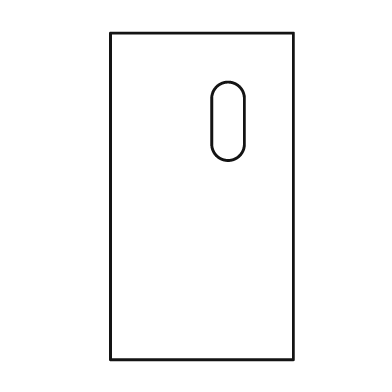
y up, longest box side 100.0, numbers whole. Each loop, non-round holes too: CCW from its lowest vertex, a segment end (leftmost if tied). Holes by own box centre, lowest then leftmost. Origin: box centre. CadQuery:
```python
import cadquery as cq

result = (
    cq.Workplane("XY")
    .moveTo(-28.0, -50.0)
    .lineTo(28.0, -50.0)
    .lineTo(28.0, 50.0)
    .lineTo(-28.0, 50.0)
    .close()
    .moveTo(3.0, 16.0)
    .threePointArc((8.0, 11.0), (13.0, 16.0))
    .lineTo(13.0, 30.0)
    .threePointArc((8.0, 35.0), (3.0, 30.0))
    .close()
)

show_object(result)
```